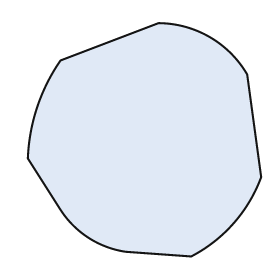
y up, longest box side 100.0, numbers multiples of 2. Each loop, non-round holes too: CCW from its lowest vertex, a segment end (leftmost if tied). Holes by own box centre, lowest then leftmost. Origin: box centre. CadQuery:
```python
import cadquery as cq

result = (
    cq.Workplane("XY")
    .moveTo(20.0, -50.0)
    .threePointArc((38.0, -36.0), (50.0, -16.0))
    .lineTo(44.0, 28.0)
    .threePointArc((28.0, 44.0), (6.0, 50.0))
    .lineTo(-36.0, 34.0)
    .threePointArc((-46.0, 14.0), (-50.0, -8.0))
    .lineTo(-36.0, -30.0)
    .threePointArc((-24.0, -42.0), (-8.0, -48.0))
    .close()
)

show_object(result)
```